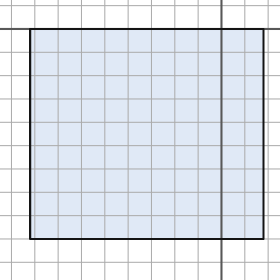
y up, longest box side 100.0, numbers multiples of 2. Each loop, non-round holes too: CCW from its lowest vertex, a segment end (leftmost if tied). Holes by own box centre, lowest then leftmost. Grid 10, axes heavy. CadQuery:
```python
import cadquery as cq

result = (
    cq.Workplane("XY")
    .moveTo(-82.0, -90.0)
    .lineTo(18.0, -90.0)
    .lineTo(18.0, 0.0)
    .lineTo(-82.0, 0.0)
    .close()
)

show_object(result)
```